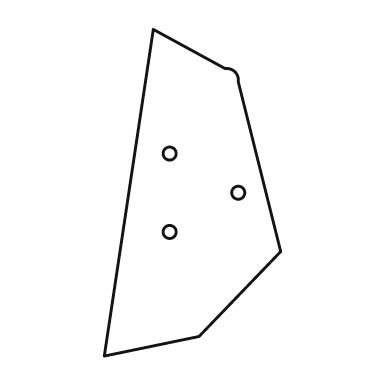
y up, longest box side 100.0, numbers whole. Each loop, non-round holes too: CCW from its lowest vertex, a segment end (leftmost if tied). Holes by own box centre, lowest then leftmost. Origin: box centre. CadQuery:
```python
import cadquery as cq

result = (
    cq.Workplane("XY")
    .moveTo(-27.0, -50.0)
    .lineTo(2.0, -44.0)
    .lineTo(27.0, -18.0)
    .lineTo(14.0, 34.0)
    .threePointArc((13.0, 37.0), (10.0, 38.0))
    .lineTo(-12.0, 50.0)
    .close()
    .moveTo(-7.0, -12.0)
    .circle(2.0)
    .moveTo(14.0, 0.0)
    .circle(2.0)
    .moveTo(-7.0, 12.0)
    .circle(2.0)
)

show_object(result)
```